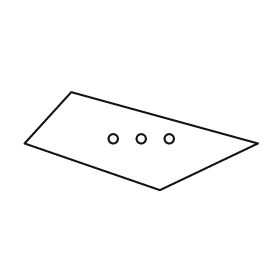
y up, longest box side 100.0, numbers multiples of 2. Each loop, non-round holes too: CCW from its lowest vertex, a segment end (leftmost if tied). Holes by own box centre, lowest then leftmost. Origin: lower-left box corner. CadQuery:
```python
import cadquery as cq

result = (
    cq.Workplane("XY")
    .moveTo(58.0, 0.0)
    .lineTo(100.0, 20.0)
    .lineTo(20.0, 42.0)
    .lineTo(0.0, 20.0)
    .close()
    .moveTo(38.0, 22.0)
    .circle(2.0)
    .moveTo(50.0, 22.0)
    .circle(2.0)
    .moveTo(62.0, 22.0)
    .circle(2.0)
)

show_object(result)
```